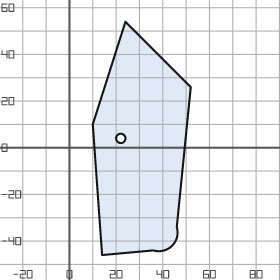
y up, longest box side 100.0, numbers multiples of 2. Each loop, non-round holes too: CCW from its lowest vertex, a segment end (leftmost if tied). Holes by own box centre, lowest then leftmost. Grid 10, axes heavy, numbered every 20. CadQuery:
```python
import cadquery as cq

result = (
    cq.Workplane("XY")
    .moveTo(14.0, -46.0)
    .lineTo(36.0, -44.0)
    .threePointArc((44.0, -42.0), (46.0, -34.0))
    .lineTo(52.0, 26.0)
    .lineTo(24.0, 54.0)
    .lineTo(10.0, 10.0)
    .close()
    .moveTo(22.0, 4.0)
    .circle(2.0)
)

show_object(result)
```